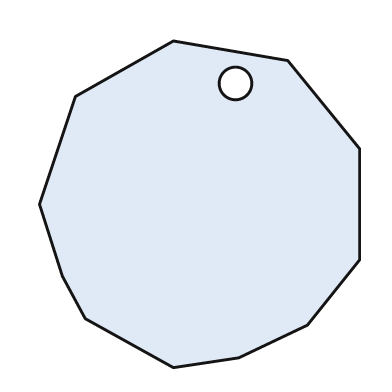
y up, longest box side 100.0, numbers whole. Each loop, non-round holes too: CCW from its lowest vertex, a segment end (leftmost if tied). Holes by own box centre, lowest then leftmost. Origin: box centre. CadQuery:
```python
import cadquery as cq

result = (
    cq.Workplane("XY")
    .moveTo(-8.0, -50.0)
    .lineTo(12.0, -47.0)
    .lineTo(33.0, -37.0)
    .lineTo(49.0, -17.0)
    .lineTo(49.0, 17.0)
    .lineTo(27.0, 44.0)
    .lineTo(-8.0, 50.0)
    .lineTo(-38.0, 33.0)
    .lineTo(-49.0, 0.0)
    .lineTo(-42.0, -22.0)
    .lineTo(-35.0, -35.0)
    .close()
    .moveTo(11.0, 37.0)
    .circle(5.0)
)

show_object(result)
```